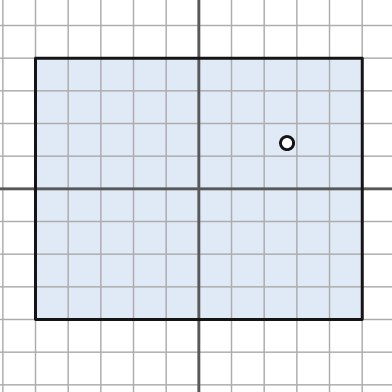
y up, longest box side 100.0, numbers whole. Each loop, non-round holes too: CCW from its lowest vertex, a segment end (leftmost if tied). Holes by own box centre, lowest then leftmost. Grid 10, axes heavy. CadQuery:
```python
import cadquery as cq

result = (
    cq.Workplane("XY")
    .moveTo(-50.0, -40.0)
    .lineTo(50.0, -40.0)
    .lineTo(50.0, 40.0)
    .lineTo(-50.0, 40.0)
    .close()
    .moveTo(27.0, 14.0)
    .circle(2.0)
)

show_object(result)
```